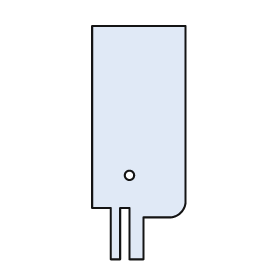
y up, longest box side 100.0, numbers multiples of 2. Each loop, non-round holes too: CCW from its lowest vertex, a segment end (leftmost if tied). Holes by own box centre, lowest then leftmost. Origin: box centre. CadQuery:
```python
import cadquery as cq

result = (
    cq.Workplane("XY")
    .moveTo(-12.0, -50.0)
    .lineTo(-8.0, -50.0)
    .lineTo(-8.0, -28.0)
    .lineTo(-4.0, -28.0)
    .lineTo(-4.0, -50.0)
    .lineTo(2.0, -50.0)
    .lineTo(2.0, -32.0)
    .lineTo(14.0, -32.0)
    .threePointArc((18.0, -30.0), (20.0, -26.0))
    .lineTo(20.0, 50.0)
    .lineTo(-20.0, 50.0)
    .lineTo(-20.0, -28.0)
    .lineTo(-12.0, -28.0)
    .close()
    .moveTo(-4.0, -14.0)
    .circle(2.0)
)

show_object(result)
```